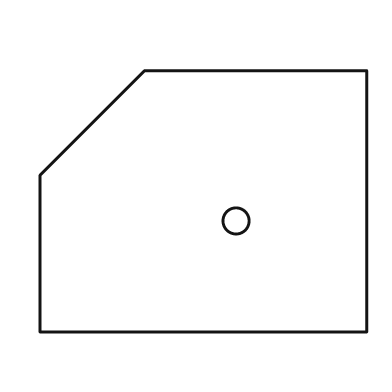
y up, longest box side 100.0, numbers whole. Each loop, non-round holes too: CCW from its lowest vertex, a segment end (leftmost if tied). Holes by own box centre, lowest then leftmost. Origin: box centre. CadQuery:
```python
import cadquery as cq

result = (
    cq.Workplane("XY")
    .moveTo(-50.0, -40.0)
    .lineTo(50.0, -40.0)
    .lineTo(50.0, 40.0)
    .lineTo(-18.0, 40.0)
    .lineTo(-50.0, 8.0)
    .close()
    .moveTo(10.0, -6.0)
    .circle(4.0)
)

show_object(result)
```